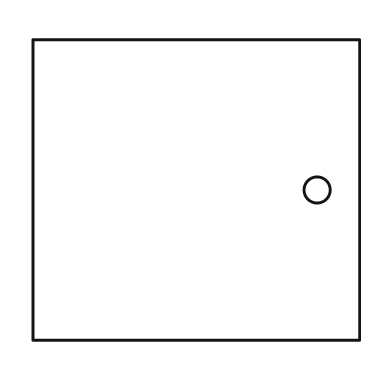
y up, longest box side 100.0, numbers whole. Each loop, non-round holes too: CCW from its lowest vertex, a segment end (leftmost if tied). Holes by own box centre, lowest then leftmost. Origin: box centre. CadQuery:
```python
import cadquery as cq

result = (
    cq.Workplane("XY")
    .moveTo(-50.0, -46.0)
    .lineTo(50.0, -46.0)
    .lineTo(50.0, 46.0)
    .lineTo(-50.0, 46.0)
    .close()
    .moveTo(37.0, 0.0)
    .circle(4.0)
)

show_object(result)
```